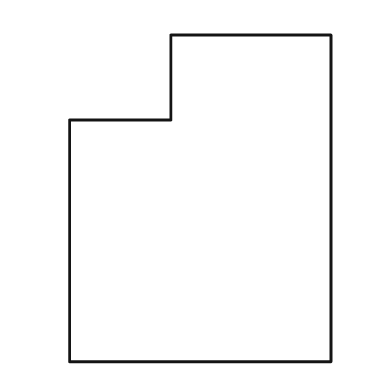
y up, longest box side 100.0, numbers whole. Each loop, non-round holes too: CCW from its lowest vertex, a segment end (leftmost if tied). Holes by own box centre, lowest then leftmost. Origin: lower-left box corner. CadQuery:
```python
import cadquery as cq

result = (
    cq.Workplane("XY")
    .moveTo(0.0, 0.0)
    .lineTo(80.0, 0.0)
    .lineTo(80.0, 100.0)
    .lineTo(31.0, 100.0)
    .lineTo(31.0, 74.0)
    .lineTo(0.0, 74.0)
    .close()
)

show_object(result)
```